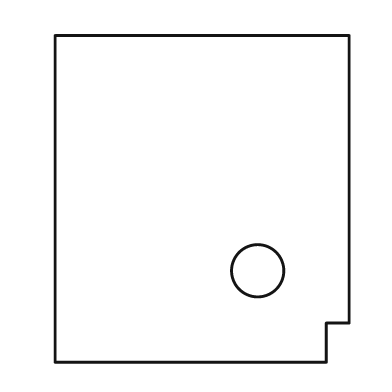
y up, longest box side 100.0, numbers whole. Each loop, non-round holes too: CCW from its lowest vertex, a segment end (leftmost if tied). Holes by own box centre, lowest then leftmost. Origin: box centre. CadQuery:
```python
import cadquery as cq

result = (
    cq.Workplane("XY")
    .moveTo(-45.0, -50.0)
    .lineTo(38.0, -50.0)
    .lineTo(38.0, -38.0)
    .lineTo(45.0, -38.0)
    .lineTo(45.0, 50.0)
    .lineTo(-45.0, 50.0)
    .close()
    .moveTo(17.0, -22.0)
    .circle(8.0)
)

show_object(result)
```